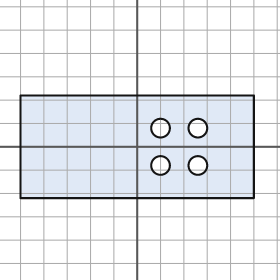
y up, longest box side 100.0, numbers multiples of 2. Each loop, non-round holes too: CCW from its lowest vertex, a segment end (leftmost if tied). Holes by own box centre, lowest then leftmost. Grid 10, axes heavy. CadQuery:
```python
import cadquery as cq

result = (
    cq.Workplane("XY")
    .moveTo(-50.0, -22.0)
    .lineTo(50.0, -22.0)
    .lineTo(50.0, 22.0)
    .lineTo(-50.0, 22.0)
    .close()
    .moveTo(10.0, -8.0)
    .circle(4.0)
    .moveTo(26.0, -8.0)
    .circle(4.0)
    .moveTo(10.0, 8.0)
    .circle(4.0)
    .moveTo(26.0, 8.0)
    .circle(4.0)
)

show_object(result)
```